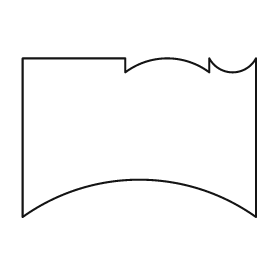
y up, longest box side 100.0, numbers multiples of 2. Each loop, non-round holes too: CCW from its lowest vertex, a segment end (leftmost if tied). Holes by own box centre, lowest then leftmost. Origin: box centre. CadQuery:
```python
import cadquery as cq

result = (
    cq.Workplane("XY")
    .moveTo(-50.0, -34.0)
    .threePointArc((0.0, -18.0), (50.0, -34.0))
    .lineTo(50.0, 34.0)
    .threePointArc((40.0, 28.0), (30.0, 34.0))
    .lineTo(30.0, 28.0)
    .threePointArc((12.0, 34.0), (-6.0, 28.0))
    .lineTo(-6.0, 34.0)
    .lineTo(-50.0, 34.0)
    .close()
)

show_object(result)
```